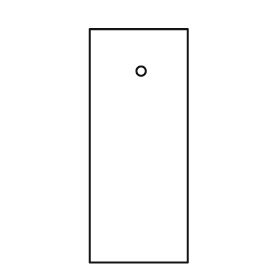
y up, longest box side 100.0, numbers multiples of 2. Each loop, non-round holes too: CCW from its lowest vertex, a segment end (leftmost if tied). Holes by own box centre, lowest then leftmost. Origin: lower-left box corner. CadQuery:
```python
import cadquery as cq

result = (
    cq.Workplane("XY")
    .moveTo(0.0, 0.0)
    .lineTo(42.0, 0.0)
    .lineTo(42.0, 100.0)
    .lineTo(0.0, 100.0)
    .close()
    .moveTo(22.0, 82.0)
    .circle(2.0)
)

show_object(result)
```